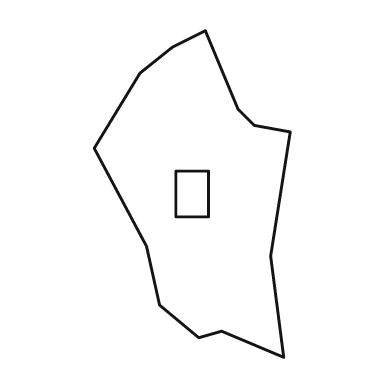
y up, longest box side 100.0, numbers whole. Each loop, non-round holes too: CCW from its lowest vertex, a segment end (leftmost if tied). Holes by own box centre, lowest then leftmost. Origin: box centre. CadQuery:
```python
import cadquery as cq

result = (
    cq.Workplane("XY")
    .moveTo(28.0, -50.0)
    .lineTo(24.0, -19.0)
    .lineTo(30.0, 19.0)
    .lineTo(19.0, 21.0)
    .lineTo(14.0, 26.0)
    .lineTo(4.0, 50.0)
    .lineTo(-6.0, 45.0)
    .lineTo(-16.0, 37.0)
    .lineTo(-30.0, 14.0)
    .lineTo(-14.0, -16.0)
    .lineTo(-10.0, -34.0)
    .lineTo(2.0, -44.0)
    .lineTo(9.0, -42.0)
    .close()
    .moveTo(-5.0, -7.0)
    .lineTo(5.0, -7.0)
    .lineTo(5.0, 7.0)
    .lineTo(-5.0, 7.0)
    .close()
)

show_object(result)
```